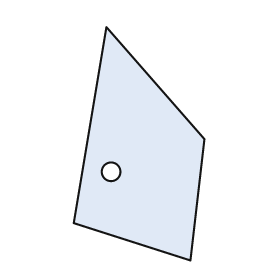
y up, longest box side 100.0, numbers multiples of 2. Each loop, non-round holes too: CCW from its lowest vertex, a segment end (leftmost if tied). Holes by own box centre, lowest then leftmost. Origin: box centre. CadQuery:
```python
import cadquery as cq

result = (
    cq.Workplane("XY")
    .moveTo(22.0, -50.0)
    .lineTo(28.0, 2.0)
    .lineTo(-14.0, 50.0)
    .lineTo(-28.0, -34.0)
    .close()
    .moveTo(-12.0, -12.0)
    .circle(4.0)
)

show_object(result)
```